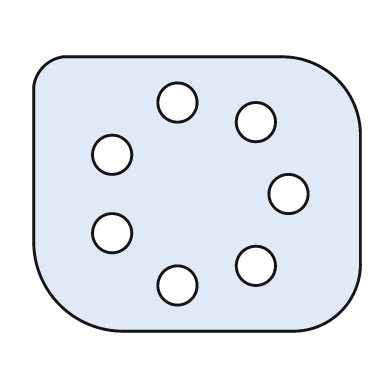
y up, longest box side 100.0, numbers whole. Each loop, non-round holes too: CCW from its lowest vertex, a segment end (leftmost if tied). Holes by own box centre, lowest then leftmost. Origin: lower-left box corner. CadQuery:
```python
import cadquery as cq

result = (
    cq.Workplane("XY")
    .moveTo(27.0, 0.0)
    .lineTo(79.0, 0.0)
    .threePointArc((94.0, 6.0), (100.0, 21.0))
    .lineTo(100.0, 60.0)
    .threePointArc((93.0, 77.0), (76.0, 84.0))
    .lineTo(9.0, 84.0)
    .threePointArc((3.0, 81.0), (0.0, 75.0))
    .lineTo(0.0, 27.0)
    .threePointArc((8.0, 8.0), (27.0, 0.0))
    .close()
    .moveTo(44.0, 14.0)
    .circle(6.0)
    .moveTo(68.0, 20.0)
    .circle(6.0)
    .moveTo(24.0, 30.0)
    .circle(6.0)
    .moveTo(78.0, 42.0)
    .circle(6.0)
    .moveTo(24.0, 54.0)
    .circle(6.0)
    .moveTo(68.0, 64.0)
    .circle(6.0)
    .moveTo(44.0, 70.0)
    .circle(6.0)
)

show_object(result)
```